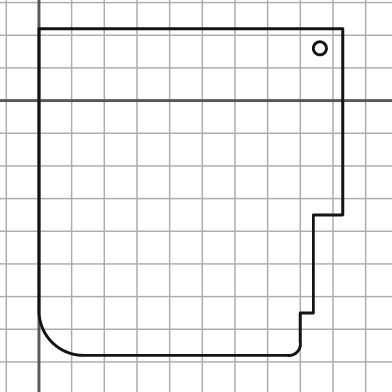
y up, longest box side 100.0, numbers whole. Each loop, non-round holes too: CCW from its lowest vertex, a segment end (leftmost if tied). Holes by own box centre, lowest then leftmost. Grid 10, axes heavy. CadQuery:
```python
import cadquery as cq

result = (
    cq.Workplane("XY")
    .moveTo(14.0, -78.0)
    .lineTo(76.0, -78.0)
    .threePointArc((79.0, -77.0), (80.0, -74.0))
    .lineTo(80.0, -65.0)
    .lineTo(84.0, -65.0)
    .lineTo(84.0, -35.0)
    .lineTo(93.0, -35.0)
    .lineTo(93.0, 22.0)
    .lineTo(0.0, 22.0)
    .lineTo(0.0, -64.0)
    .threePointArc((4.0, -74.0), (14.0, -78.0))
    .close()
    .moveTo(86.0, 16.0)
    .circle(2.0)
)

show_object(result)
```